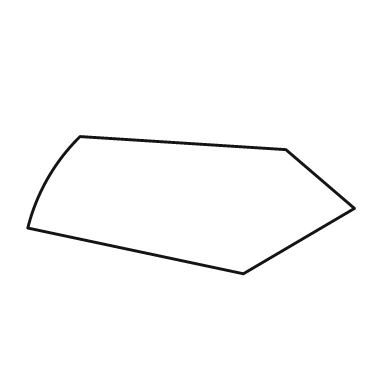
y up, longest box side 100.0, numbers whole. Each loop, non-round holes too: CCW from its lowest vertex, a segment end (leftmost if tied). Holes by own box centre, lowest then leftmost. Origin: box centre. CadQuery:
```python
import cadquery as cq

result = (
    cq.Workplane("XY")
    .moveTo(16.0, -21.0)
    .lineTo(50.0, -1.0)
    .lineTo(29.0, 17.0)
    .lineTo(-34.0, 21.0)
    .threePointArc((-44.0, 8.0), (-50.0, -7.0))
    .close()
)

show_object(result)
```